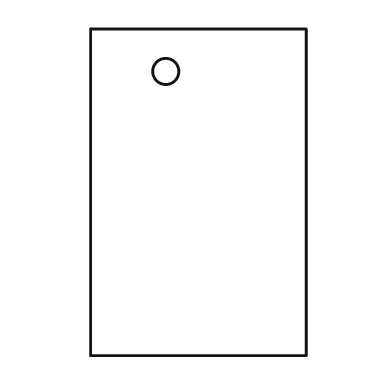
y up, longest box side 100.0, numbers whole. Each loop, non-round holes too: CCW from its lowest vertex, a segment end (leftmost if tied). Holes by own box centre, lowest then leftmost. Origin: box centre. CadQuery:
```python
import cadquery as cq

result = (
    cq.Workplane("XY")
    .moveTo(-33.0, -50.0)
    .lineTo(33.0, -50.0)
    .lineTo(33.0, 50.0)
    .lineTo(-33.0, 50.0)
    .close()
    .moveTo(-10.0, 37.0)
    .circle(4.0)
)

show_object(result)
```